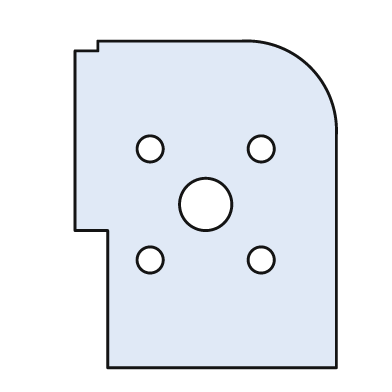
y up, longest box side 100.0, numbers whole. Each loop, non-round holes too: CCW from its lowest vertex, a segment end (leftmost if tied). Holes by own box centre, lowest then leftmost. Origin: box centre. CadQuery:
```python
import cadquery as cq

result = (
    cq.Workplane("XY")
    .moveTo(-30.0, -50.0)
    .lineTo(40.0, -50.0)
    .lineTo(40.0, 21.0)
    .threePointArc((32.0, 42.0), (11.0, 50.0))
    .lineTo(-33.0, 50.0)
    .lineTo(-33.0, 47.0)
    .lineTo(-40.0, 47.0)
    .lineTo(-40.0, -8.0)
    .lineTo(-30.0, -8.0)
    .close()
    .moveTo(-17.0, -17.0)
    .circle(4.0)
    .moveTo(17.0, -17.0)
    .circle(4.0)
    .moveTo(0.0, 0.0)
    .circle(8.0)
    .moveTo(-17.0, 17.0)
    .circle(4.0)
    .moveTo(17.0, 17.0)
    .circle(4.0)
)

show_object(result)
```